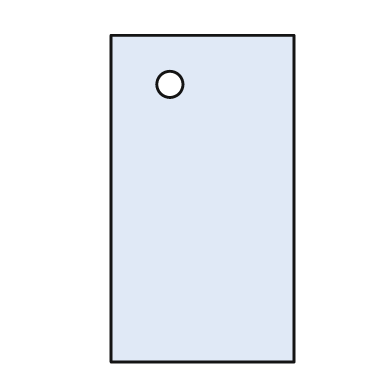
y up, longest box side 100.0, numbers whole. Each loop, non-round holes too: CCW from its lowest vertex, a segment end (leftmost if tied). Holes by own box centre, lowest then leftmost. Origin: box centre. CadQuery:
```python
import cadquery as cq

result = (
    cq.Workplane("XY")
    .moveTo(-28.0, -50.0)
    .lineTo(28.0, -50.0)
    .lineTo(28.0, 50.0)
    .lineTo(-28.0, 50.0)
    .close()
    .moveTo(-10.0, 35.0)
    .circle(4.0)
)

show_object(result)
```